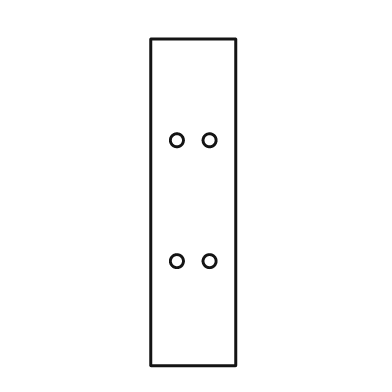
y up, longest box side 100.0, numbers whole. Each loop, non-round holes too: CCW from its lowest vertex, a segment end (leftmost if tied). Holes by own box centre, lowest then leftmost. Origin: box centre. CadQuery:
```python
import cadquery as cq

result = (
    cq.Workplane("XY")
    .moveTo(-13.0, -50.0)
    .lineTo(13.0, -50.0)
    .lineTo(13.0, 50.0)
    .lineTo(-13.0, 50.0)
    .close()
    .moveTo(-5.0, -18.0)
    .circle(2.0)
    .moveTo(5.0, -18.0)
    .circle(2.0)
    .moveTo(-5.0, 19.0)
    .circle(2.0)
    .moveTo(5.0, 19.0)
    .circle(2.0)
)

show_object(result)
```